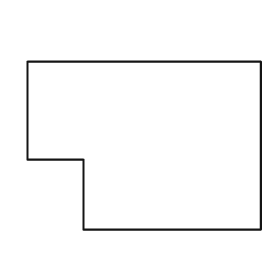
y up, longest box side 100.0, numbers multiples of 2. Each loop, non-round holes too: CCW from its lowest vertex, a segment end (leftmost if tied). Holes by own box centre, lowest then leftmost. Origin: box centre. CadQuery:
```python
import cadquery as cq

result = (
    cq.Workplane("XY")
    .moveTo(-26.0, -36.0)
    .lineTo(50.0, -36.0)
    .lineTo(50.0, 36.0)
    .lineTo(-50.0, 36.0)
    .lineTo(-50.0, -6.0)
    .lineTo(-26.0, -6.0)
    .close()
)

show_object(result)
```